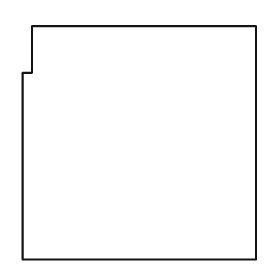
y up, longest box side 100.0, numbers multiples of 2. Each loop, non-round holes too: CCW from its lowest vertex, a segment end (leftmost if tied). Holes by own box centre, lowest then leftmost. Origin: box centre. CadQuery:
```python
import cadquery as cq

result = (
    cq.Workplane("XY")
    .moveTo(-50.0, -50.0)
    .lineTo(50.0, -50.0)
    .lineTo(50.0, 50.0)
    .lineTo(-46.0, 50.0)
    .lineTo(-46.0, 30.0)
    .lineTo(-50.0, 30.0)
    .close()
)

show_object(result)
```